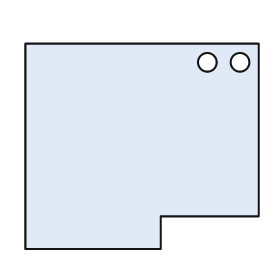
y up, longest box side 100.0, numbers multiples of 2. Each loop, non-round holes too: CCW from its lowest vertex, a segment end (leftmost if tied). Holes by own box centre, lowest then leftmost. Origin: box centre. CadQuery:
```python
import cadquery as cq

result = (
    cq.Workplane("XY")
    .moveTo(-50.0, -44.0)
    .lineTo(8.0, -44.0)
    .lineTo(8.0, -30.0)
    .lineTo(50.0, -30.0)
    .lineTo(50.0, 44.0)
    .lineTo(-50.0, 44.0)
    .close()
    .moveTo(28.0, 36.0)
    .circle(4.0)
    .moveTo(42.0, 36.0)
    .circle(4.0)
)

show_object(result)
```